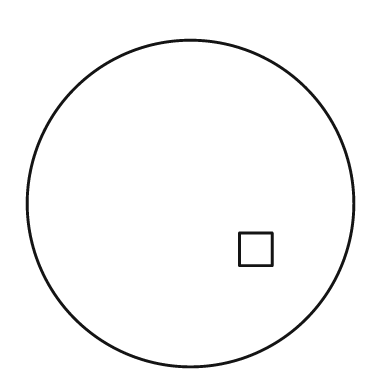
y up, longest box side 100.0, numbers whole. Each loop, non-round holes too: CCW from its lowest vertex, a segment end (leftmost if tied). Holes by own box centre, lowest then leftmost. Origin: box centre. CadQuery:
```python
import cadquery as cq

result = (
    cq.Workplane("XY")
    .moveTo(0.0, 0.0)
    .circle(50.0)
    .moveTo(15.0, -19.0)
    .lineTo(25.0, -19.0)
    .lineTo(25.0, -9.0)
    .lineTo(15.0, -9.0)
    .close()
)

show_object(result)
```